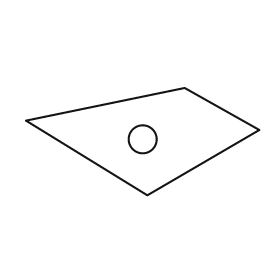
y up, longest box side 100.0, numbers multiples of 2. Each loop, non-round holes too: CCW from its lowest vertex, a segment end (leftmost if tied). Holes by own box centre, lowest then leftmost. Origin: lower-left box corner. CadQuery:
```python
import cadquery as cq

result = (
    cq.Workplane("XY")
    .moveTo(52.0, 0.0)
    .lineTo(100.0, 28.0)
    .lineTo(68.0, 46.0)
    .lineTo(0.0, 32.0)
    .close()
    .moveTo(50.0, 24.0)
    .circle(6.0)
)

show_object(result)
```